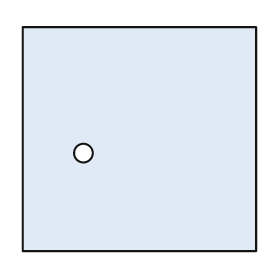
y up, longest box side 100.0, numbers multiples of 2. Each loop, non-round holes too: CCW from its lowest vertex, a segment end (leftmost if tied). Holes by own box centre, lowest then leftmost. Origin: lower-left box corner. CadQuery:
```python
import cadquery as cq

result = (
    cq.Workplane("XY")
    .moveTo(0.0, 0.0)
    .lineTo(100.0, 0.0)
    .lineTo(100.0, 96.0)
    .lineTo(0.0, 96.0)
    .close()
    .moveTo(26.0, 42.0)
    .circle(4.0)
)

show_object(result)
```